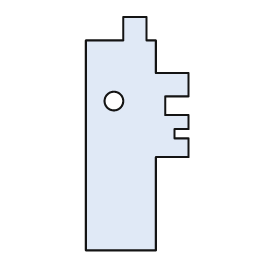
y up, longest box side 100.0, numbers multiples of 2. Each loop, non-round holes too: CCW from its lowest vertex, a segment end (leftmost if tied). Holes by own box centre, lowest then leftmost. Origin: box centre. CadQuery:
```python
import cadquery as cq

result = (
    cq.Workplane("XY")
    .moveTo(-22.0, -50.0)
    .lineTo(8.0, -50.0)
    .lineTo(8.0, -10.0)
    .lineTo(22.0, -10.0)
    .lineTo(22.0, -2.0)
    .lineTo(16.0, -2.0)
    .lineTo(16.0, 2.0)
    .lineTo(22.0, 2.0)
    .lineTo(22.0, 8.0)
    .lineTo(12.0, 8.0)
    .lineTo(12.0, 16.0)
    .lineTo(22.0, 16.0)
    .lineTo(22.0, 26.0)
    .lineTo(8.0, 26.0)
    .lineTo(8.0, 40.0)
    .lineTo(4.0, 40.0)
    .lineTo(4.0, 50.0)
    .lineTo(-6.0, 50.0)
    .lineTo(-6.0, 40.0)
    .lineTo(-22.0, 40.0)
    .close()
    .moveTo(-10.0, 14.0)
    .circle(4.0)
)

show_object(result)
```